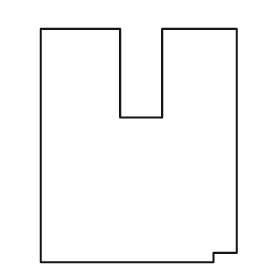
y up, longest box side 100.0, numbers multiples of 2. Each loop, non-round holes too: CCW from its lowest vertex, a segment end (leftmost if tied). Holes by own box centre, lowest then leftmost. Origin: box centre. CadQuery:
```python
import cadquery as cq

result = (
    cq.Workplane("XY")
    .moveTo(-42.0, -50.0)
    .lineTo(32.0, -50.0)
    .lineTo(32.0, -46.0)
    .lineTo(42.0, -46.0)
    .lineTo(42.0, 50.0)
    .lineTo(10.0, 50.0)
    .lineTo(10.0, 12.0)
    .lineTo(-8.0, 12.0)
    .lineTo(-8.0, 50.0)
    .lineTo(-42.0, 50.0)
    .close()
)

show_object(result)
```